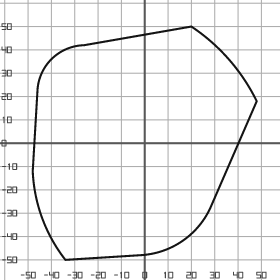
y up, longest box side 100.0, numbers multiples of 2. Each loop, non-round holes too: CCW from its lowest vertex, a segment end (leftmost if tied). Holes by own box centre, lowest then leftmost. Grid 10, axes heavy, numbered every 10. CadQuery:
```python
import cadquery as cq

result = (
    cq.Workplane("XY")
    .moveTo(-34.0, -50.0)
    .lineTo(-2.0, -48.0)
    .threePointArc((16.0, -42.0), (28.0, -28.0))
    .lineTo(48.0, 18.0)
    .threePointArc((36.0, 36.0), (20.0, 50.0))
    .lineTo(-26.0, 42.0)
    .threePointArc((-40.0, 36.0), (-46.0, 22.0))
    .lineTo(-48.0, -12.0)
    .threePointArc((-44.0, -32.0), (-34.0, -50.0))
    .close()
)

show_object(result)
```